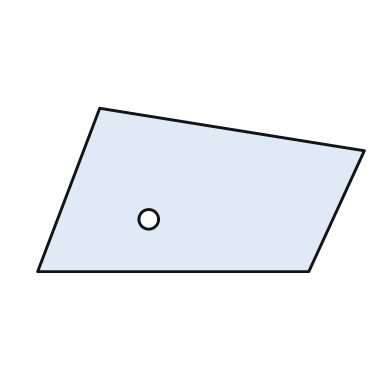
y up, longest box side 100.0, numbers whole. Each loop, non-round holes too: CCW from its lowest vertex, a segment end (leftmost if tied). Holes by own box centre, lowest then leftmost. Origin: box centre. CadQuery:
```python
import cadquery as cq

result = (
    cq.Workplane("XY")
    .moveTo(-50.0, -25.0)
    .lineTo(33.0, -25.0)
    .lineTo(50.0, 12.0)
    .lineTo(-31.0, 25.0)
    .close()
    .moveTo(-16.0, -9.0)
    .circle(3.0)
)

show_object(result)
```